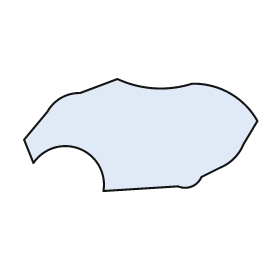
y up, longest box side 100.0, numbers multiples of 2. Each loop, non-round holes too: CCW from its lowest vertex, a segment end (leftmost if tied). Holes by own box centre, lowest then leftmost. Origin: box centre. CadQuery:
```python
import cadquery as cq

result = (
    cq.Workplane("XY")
    .moveTo(-16.0, -24.0)
    .lineTo(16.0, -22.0)
    .threePointArc((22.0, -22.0), (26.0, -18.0))
    .lineTo(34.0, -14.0)
    .threePointArc((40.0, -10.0), (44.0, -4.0))
    .lineTo(50.0, 6.0)
    .threePointArc((38.0, 18.0), (22.0, 22.0))
    .threePointArc((6.0, 20.0), (-10.0, 24.0))
    .lineTo(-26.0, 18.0)
    .threePointArc((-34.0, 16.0), (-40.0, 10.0))
    .lineTo(-50.0, -2.0)
    .lineTo(-46.0, -12.0)
    .threePointArc((-26.0, -6.0), (-16.0, -24.0))
    .close()
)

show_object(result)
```